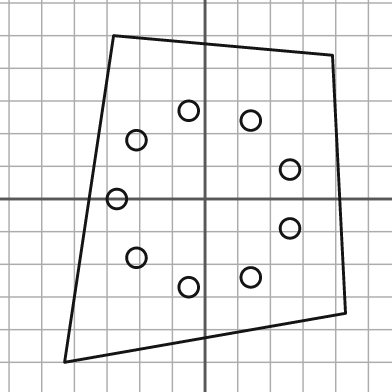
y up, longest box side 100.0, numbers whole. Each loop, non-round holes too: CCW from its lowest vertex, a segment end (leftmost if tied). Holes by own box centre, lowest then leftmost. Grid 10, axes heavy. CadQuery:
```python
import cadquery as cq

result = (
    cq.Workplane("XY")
    .moveTo(-43.0, -50.0)
    .lineTo(43.0, -35.0)
    .lineTo(39.0, 44.0)
    .lineTo(-28.0, 50.0)
    .close()
    .moveTo(-5.0, -27.0)
    .circle(3.0)
    .moveTo(14.0, -24.0)
    .circle(3.0)
    .moveTo(-21.0, -18.0)
    .circle(3.0)
    .moveTo(26.0, -9.0)
    .circle(3.0)
    .moveTo(-27.0, 0.0)
    .circle(3.0)
    .moveTo(26.0, 9.0)
    .circle(3.0)
    .moveTo(-21.0, 18.0)
    .circle(3.0)
    .moveTo(14.0, 24.0)
    .circle(3.0)
    .moveTo(-5.0, 27.0)
    .circle(3.0)
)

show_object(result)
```